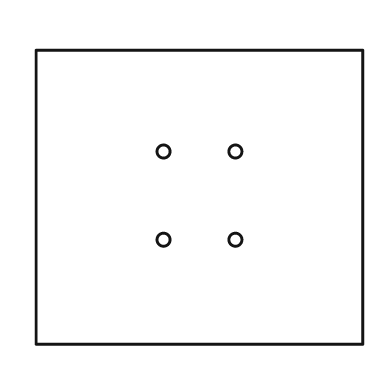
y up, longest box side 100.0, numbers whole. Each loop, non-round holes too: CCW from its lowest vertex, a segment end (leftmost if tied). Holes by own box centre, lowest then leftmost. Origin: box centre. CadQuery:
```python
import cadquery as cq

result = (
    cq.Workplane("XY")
    .moveTo(-50.0, -45.0)
    .lineTo(50.0, -45.0)
    .lineTo(50.0, 45.0)
    .lineTo(-50.0, 45.0)
    .close()
    .moveTo(-11.0, -13.0)
    .circle(2.0)
    .moveTo(11.0, -13.0)
    .circle(2.0)
    .moveTo(-11.0, 14.0)
    .circle(2.0)
    .moveTo(11.0, 14.0)
    .circle(2.0)
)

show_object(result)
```